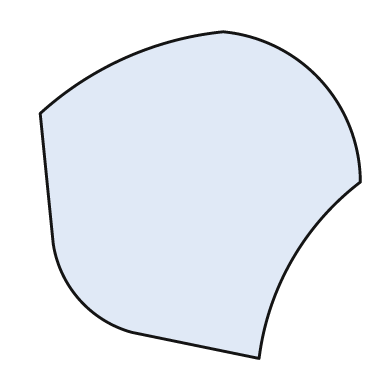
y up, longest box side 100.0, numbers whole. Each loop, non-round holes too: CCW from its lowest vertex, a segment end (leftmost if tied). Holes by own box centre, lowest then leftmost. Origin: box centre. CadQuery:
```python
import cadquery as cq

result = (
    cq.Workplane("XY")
    .moveTo(18.0, -50.0)
    .threePointArc((28.0, -20.0), (49.0, 4.0))
    .threePointArc((37.0, 35.0), (7.0, 50.0))
    .threePointArc((-23.0, 42.0), (-49.0, 25.0))
    .lineTo(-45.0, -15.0)
    .threePointArc((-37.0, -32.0), (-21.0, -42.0))
    .close()
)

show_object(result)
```